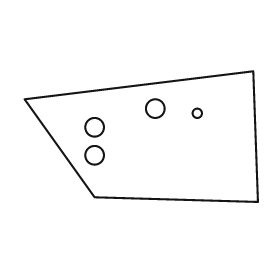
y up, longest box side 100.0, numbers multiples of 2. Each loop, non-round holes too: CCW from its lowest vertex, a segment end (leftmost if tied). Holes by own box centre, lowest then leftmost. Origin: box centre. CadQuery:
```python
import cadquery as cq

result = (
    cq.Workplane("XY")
    .moveTo(50.0, -28.0)
    .lineTo(48.0, 28.0)
    .lineTo(-50.0, 16.0)
    .lineTo(-20.0, -26.0)
    .close()
    .moveTo(-20.0, -8.0)
    .circle(4.0)
    .moveTo(-20.0, 4.0)
    .circle(4.0)
    .moveTo(24.0, 10.0)
    .circle(2.0)
    .moveTo(6.0, 12.0)
    .circle(4.0)
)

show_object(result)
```